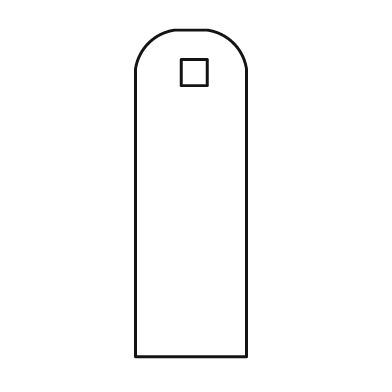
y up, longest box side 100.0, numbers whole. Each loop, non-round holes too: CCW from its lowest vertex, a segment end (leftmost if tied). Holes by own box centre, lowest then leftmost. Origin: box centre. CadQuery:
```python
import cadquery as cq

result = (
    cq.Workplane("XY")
    .moveTo(-17.0, -50.0)
    .lineTo(17.0, -50.0)
    .lineTo(17.0, 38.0)
    .threePointArc((13.0, 46.0), (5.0, 50.0))
    .lineTo(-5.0, 50.0)
    .threePointArc((-13.0, 46.0), (-17.0, 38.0))
    .close()
    .moveTo(-3.0, 33.0)
    .lineTo(5.0, 33.0)
    .lineTo(5.0, 41.0)
    .lineTo(-3.0, 41.0)
    .close()
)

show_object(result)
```